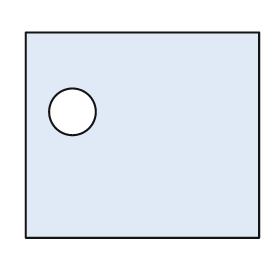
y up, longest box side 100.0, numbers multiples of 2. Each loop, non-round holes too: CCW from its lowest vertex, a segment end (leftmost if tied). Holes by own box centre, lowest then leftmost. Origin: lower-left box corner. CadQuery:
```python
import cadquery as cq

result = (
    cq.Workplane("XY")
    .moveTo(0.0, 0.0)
    .lineTo(100.0, 0.0)
    .lineTo(100.0, 88.0)
    .lineTo(0.0, 88.0)
    .close()
    .moveTo(20.0, 54.0)
    .circle(10.0)
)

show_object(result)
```